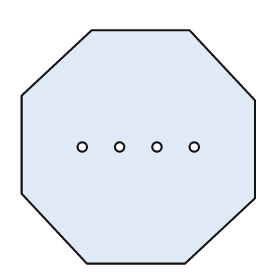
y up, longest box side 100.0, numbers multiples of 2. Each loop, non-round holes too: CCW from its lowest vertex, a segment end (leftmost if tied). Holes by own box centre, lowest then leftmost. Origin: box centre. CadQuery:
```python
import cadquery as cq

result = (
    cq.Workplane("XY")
    .moveTo(-22.0, -50.0)
    .lineTo(20.0, -50.0)
    .lineTo(50.0, -22.0)
    .lineTo(50.0, 20.0)
    .lineTo(22.0, 50.0)
    .lineTo(-20.0, 50.0)
    .lineTo(-50.0, 22.0)
    .lineTo(-50.0, -20.0)
    .close()
    .moveTo(-24.0, 0.0)
    .circle(2.0)
    .moveTo(-8.0, 0.0)
    .circle(2.0)
    .moveTo(8.0, 0.0)
    .circle(2.0)
    .moveTo(24.0, 0.0)
    .circle(2.0)
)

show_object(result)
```